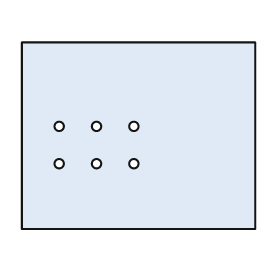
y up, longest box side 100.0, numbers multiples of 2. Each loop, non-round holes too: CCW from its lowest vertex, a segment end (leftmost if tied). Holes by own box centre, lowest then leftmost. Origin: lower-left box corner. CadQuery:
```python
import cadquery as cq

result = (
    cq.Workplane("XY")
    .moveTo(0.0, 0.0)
    .lineTo(100.0, 0.0)
    .lineTo(100.0, 80.0)
    .lineTo(0.0, 80.0)
    .close()
    .moveTo(16.0, 28.0)
    .circle(2.0)
    .moveTo(32.0, 28.0)
    .circle(2.0)
    .moveTo(48.0, 28.0)
    .circle(2.0)
    .moveTo(16.0, 44.0)
    .circle(2.0)
    .moveTo(32.0, 44.0)
    .circle(2.0)
    .moveTo(48.0, 44.0)
    .circle(2.0)
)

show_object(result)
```